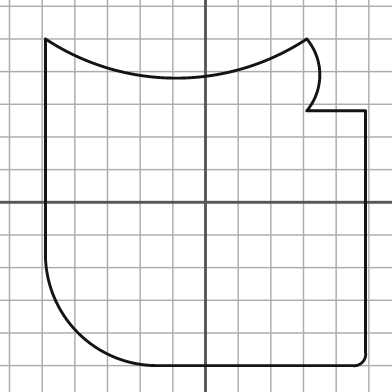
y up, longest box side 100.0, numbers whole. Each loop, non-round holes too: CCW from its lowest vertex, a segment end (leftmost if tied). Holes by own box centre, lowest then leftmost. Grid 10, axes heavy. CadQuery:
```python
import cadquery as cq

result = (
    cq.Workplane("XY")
    .moveTo(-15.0, -50.0)
    .lineTo(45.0, -50.0)
    .threePointArc((48.0, -49.0), (49.0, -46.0))
    .lineTo(49.0, 28.0)
    .lineTo(31.0, 28.0)
    .threePointArc((35.0, 39.0), (31.0, 50.0))
    .threePointArc((-9.0, 38.0), (-49.0, 50.0))
    .lineTo(-49.0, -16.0)
    .threePointArc((-39.0, -40.0), (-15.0, -50.0))
    .close()
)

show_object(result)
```